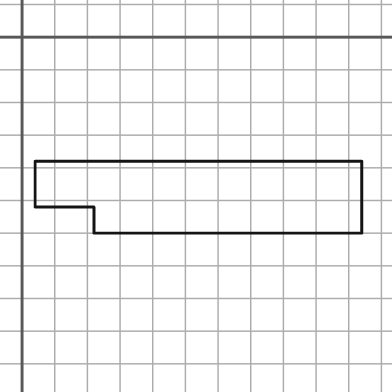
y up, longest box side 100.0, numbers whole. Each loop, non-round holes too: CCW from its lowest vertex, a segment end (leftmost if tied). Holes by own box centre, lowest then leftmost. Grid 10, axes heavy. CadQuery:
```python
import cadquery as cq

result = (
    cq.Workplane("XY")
    .moveTo(22.0, -60.0)
    .lineTo(104.0, -60.0)
    .lineTo(104.0, -38.0)
    .lineTo(4.0, -38.0)
    .lineTo(4.0, -52.0)
    .lineTo(22.0, -52.0)
    .close()
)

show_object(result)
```